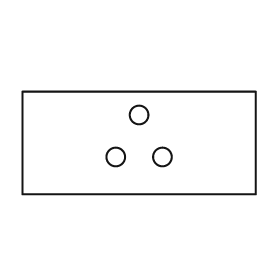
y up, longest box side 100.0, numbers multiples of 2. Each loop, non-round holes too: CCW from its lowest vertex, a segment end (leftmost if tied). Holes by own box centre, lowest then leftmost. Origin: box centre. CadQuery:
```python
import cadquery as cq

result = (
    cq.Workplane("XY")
    .moveTo(-50.0, -22.0)
    .lineTo(50.0, -22.0)
    .lineTo(50.0, 22.0)
    .lineTo(-50.0, 22.0)
    .close()
    .moveTo(-10.0, -6.0)
    .circle(4.0)
    .moveTo(10.0, -6.0)
    .circle(4.0)
    .moveTo(0.0, 12.0)
    .circle(4.0)
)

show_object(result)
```